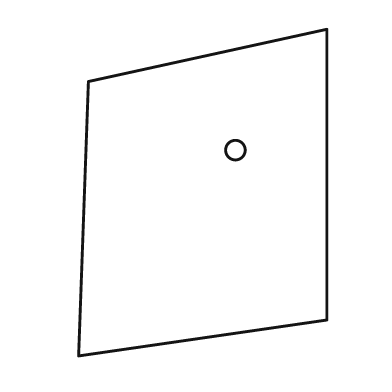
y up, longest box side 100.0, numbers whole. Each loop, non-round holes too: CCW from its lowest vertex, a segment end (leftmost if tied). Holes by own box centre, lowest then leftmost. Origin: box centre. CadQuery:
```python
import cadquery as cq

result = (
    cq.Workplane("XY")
    .moveTo(-38.0, -50.0)
    .lineTo(38.0, -39.0)
    .lineTo(38.0, 50.0)
    .lineTo(-35.0, 34.0)
    .close()
    .moveTo(10.0, 13.0)
    .circle(3.0)
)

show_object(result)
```